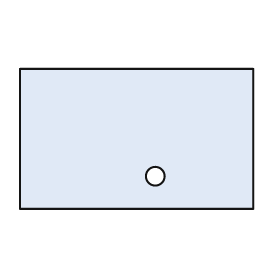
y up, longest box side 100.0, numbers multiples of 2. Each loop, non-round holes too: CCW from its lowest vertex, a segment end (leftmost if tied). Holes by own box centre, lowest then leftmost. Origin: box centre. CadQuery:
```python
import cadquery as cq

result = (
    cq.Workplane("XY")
    .moveTo(-50.0, -30.0)
    .lineTo(50.0, -30.0)
    .lineTo(50.0, 30.0)
    .lineTo(-50.0, 30.0)
    .close()
    .moveTo(8.0, -16.0)
    .circle(4.0)
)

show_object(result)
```